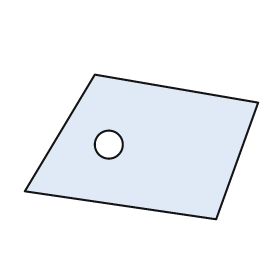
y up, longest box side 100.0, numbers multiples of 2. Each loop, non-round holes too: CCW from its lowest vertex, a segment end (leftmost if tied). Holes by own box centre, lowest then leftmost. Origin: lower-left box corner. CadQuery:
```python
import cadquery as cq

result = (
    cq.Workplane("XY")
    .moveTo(82.0, 0.0)
    .lineTo(100.0, 50.0)
    .lineTo(30.0, 62.0)
    .lineTo(0.0, 12.0)
    .close()
    .moveTo(36.0, 32.0)
    .circle(6.0)
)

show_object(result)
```